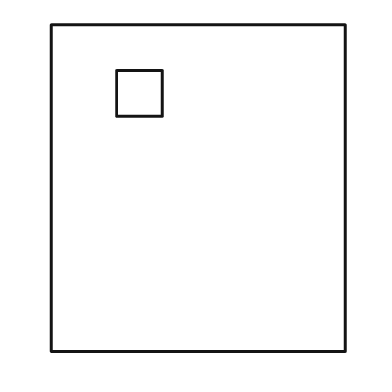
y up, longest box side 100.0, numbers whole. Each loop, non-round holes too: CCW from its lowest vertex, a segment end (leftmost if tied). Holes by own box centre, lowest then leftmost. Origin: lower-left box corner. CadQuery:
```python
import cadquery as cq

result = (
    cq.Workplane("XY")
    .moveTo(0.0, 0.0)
    .lineTo(90.0, 0.0)
    .lineTo(90.0, 100.0)
    .lineTo(0.0, 100.0)
    .close()
    .moveTo(20.0, 72.0)
    .lineTo(34.0, 72.0)
    .lineTo(34.0, 86.0)
    .lineTo(20.0, 86.0)
    .close()
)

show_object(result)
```